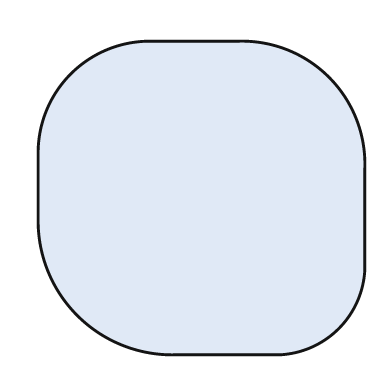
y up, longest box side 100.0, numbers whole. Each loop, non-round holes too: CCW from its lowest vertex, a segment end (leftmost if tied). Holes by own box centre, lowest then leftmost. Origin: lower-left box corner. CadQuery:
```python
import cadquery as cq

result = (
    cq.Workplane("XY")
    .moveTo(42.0, 0.0)
    .lineTo(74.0, 0.0)
    .threePointArc((92.0, 8.0), (100.0, 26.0))
    .lineTo(100.0, 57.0)
    .threePointArc((89.0, 85.0), (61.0, 96.0))
    .lineTo(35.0, 96.0)
    .threePointArc((10.0, 86.0), (0.0, 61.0))
    .lineTo(0.0, 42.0)
    .threePointArc((12.0, 12.0), (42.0, 0.0))
    .close()
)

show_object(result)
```